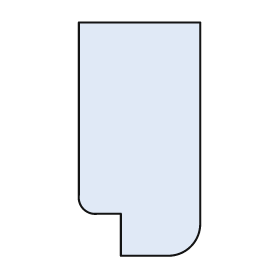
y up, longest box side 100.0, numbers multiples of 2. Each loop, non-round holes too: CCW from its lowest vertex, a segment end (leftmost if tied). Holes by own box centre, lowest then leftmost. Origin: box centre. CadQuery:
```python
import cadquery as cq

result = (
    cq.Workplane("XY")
    .moveTo(-8.0, -50.0)
    .lineTo(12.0, -50.0)
    .threePointArc((22.0, -46.0), (26.0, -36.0))
    .lineTo(26.0, 50.0)
    .lineTo(-26.0, 50.0)
    .lineTo(-26.0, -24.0)
    .threePointArc((-24.0, -30.0), (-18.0, -32.0))
    .lineTo(-8.0, -32.0)
    .close()
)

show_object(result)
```